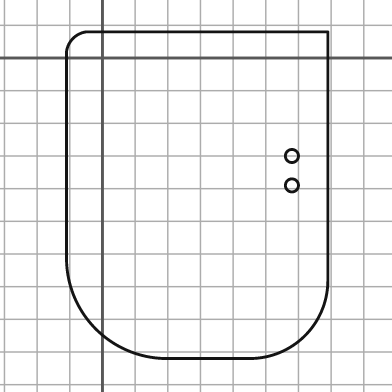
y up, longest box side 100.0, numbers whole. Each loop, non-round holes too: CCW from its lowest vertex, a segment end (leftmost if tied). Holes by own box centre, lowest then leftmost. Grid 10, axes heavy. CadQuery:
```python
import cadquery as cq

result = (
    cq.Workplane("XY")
    .moveTo(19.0, -92.0)
    .lineTo(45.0, -92.0)
    .threePointArc((62.0, -85.0), (69.0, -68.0))
    .lineTo(69.0, 8.0)
    .lineTo(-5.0, 8.0)
    .threePointArc((-9.0, 6.0), (-11.0, 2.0))
    .lineTo(-11.0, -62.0)
    .threePointArc((-2.0, -83.0), (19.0, -92.0))
    .close()
    .moveTo(58.0, -39.0)
    .circle(2.0)
    .moveTo(58.0, -30.0)
    .circle(2.0)
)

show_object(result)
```